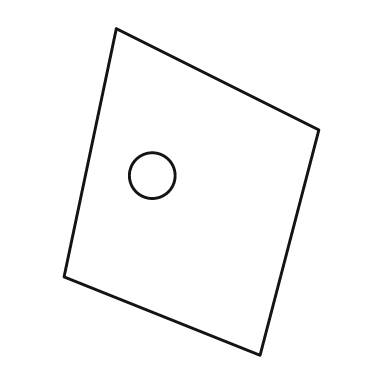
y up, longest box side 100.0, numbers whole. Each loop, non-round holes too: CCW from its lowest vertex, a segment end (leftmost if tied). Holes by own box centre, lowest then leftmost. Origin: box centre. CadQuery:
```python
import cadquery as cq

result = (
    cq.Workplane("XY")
    .moveTo(21.0, -50.0)
    .lineTo(39.0, 19.0)
    .lineTo(-23.0, 50.0)
    .lineTo(-39.0, -26.0)
    .close()
    .moveTo(-12.0, 5.0)
    .circle(7.0)
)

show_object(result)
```